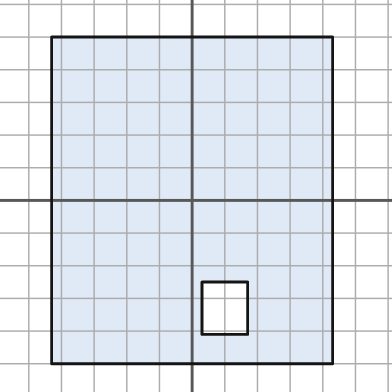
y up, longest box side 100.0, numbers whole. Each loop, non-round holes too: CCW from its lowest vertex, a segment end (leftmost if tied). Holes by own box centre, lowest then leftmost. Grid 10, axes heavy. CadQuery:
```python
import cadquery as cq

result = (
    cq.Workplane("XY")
    .moveTo(-43.0, -50.0)
    .lineTo(43.0, -50.0)
    .lineTo(43.0, 50.0)
    .lineTo(-43.0, 50.0)
    .close()
    .moveTo(3.0, -41.0)
    .lineTo(17.0, -41.0)
    .lineTo(17.0, -25.0)
    .lineTo(3.0, -25.0)
    .close()
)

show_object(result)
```